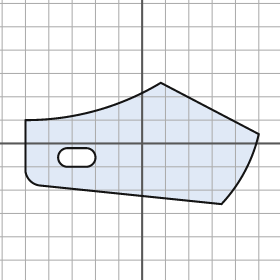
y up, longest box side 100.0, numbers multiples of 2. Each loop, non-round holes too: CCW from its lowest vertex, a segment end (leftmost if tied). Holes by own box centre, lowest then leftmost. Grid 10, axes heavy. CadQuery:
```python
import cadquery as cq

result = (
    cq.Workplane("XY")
    .moveTo(34.0, -26.0)
    .threePointArc((44.0, -12.0), (50.0, 4.0))
    .lineTo(8.0, 26.0)
    .threePointArc((-20.0, 14.0), (-50.0, 10.0))
    .lineTo(-50.0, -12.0)
    .threePointArc((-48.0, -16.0), (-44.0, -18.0))
    .close()
    .moveTo(-32.0, -10.0)
    .lineTo(-24.0, -10.0)
    .threePointArc((-20.0, -6.0), (-24.0, -2.0))
    .lineTo(-32.0, -2.0)
    .threePointArc((-36.0, -6.0), (-32.0, -10.0))
    .close()
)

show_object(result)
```